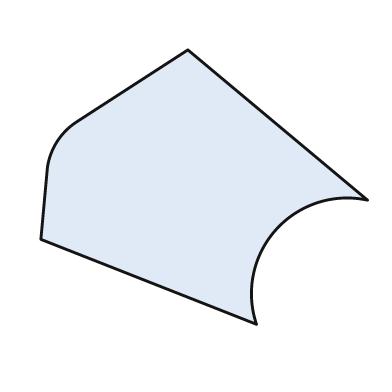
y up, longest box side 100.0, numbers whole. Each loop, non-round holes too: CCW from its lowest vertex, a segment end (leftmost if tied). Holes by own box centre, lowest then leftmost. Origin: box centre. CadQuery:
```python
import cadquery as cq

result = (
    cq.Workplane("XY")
    .moveTo(16.0, -42.0)
    .threePointArc((22.0, -13.0), (50.0, -4.0))
    .lineTo(-5.0, 42.0)
    .lineTo(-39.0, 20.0)
    .threePointArc((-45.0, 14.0), (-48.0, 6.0))
    .lineTo(-50.0, -16.0)
    .close()
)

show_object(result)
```